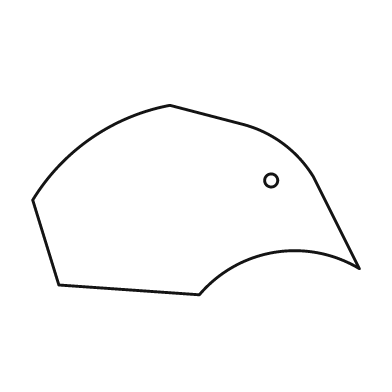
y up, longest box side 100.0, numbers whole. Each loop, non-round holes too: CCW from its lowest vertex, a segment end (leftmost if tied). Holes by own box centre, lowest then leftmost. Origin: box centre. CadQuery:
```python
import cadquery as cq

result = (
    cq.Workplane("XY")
    .moveTo(1.0, -29.0)
    .threePointArc((24.0, -16.0), (50.0, -21.0))
    .lineTo(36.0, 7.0)
    .threePointArc((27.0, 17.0), (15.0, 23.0))
    .lineTo(-8.0, 29.0)
    .threePointArc((-32.0, 19.0), (-50.0, 0.0))
    .lineTo(-42.0, -26.0)
    .close()
    .moveTo(23.0, 6.0)
    .circle(2.0)
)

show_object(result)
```